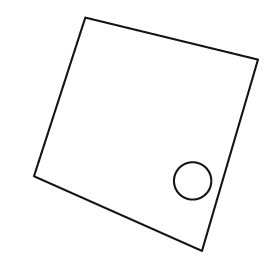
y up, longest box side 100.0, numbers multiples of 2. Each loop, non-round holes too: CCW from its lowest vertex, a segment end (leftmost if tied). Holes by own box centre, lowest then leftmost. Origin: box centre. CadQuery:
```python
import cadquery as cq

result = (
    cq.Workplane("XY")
    .moveTo(24.0, -50.0)
    .lineTo(48.0, 32.0)
    .lineTo(-26.0, 50.0)
    .lineTo(-48.0, -18.0)
    .close()
    .moveTo(20.0, -20.0)
    .circle(8.0)
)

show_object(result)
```